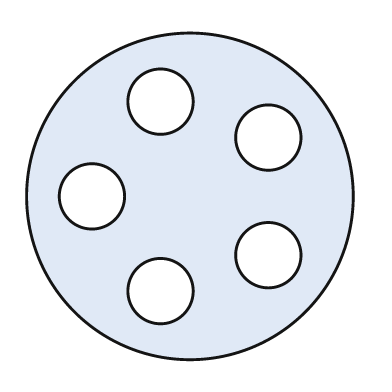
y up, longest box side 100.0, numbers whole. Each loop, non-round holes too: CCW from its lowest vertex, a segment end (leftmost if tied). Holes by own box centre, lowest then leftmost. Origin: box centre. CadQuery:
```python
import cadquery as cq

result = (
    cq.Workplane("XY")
    .moveTo(0.0, 0.0)
    .circle(50.0)
    .moveTo(-9.0, -29.0)
    .circle(10.0)
    .moveTo(24.0, -18.0)
    .circle(10.0)
    .moveTo(-30.0, 0.0)
    .circle(10.0)
    .moveTo(24.0, 18.0)
    .circle(10.0)
    .moveTo(-9.0, 29.0)
    .circle(10.0)
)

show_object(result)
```